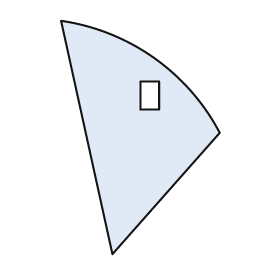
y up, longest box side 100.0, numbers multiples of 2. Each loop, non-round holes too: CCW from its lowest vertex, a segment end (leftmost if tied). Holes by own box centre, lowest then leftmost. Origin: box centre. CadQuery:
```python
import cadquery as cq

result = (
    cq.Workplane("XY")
    .moveTo(-12.0, -50.0)
    .lineTo(34.0, 2.0)
    .threePointArc((6.0, 34.0), (-34.0, 50.0))
    .close()
    .moveTo(0.0, 12.0)
    .lineTo(8.0, 12.0)
    .lineTo(8.0, 24.0)
    .lineTo(0.0, 24.0)
    .close()
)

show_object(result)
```